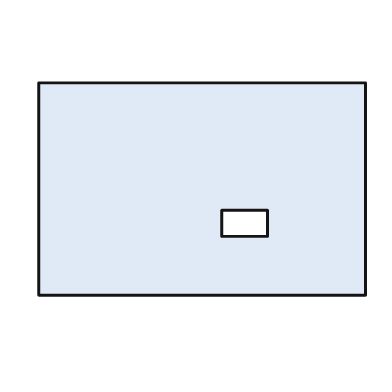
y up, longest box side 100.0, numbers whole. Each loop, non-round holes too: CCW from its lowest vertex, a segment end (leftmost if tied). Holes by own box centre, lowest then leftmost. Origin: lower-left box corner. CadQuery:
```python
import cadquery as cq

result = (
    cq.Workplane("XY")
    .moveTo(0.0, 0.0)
    .lineTo(100.0, 0.0)
    .lineTo(100.0, 65.0)
    .lineTo(0.0, 65.0)
    .close()
    .moveTo(56.0, 18.0)
    .lineTo(70.0, 18.0)
    .lineTo(70.0, 26.0)
    .lineTo(56.0, 26.0)
    .close()
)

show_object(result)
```